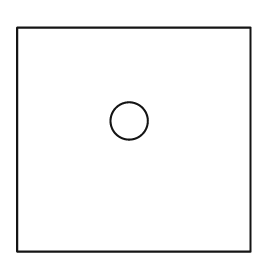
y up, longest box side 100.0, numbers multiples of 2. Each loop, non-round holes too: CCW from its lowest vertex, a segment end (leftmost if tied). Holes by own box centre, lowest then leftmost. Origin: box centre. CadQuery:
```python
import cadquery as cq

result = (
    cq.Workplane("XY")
    .moveTo(-50.0, -48.0)
    .lineTo(50.0, -48.0)
    .lineTo(50.0, 48.0)
    .lineTo(-50.0, 48.0)
    .close()
    .moveTo(-2.0, 8.0)
    .circle(8.0)
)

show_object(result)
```